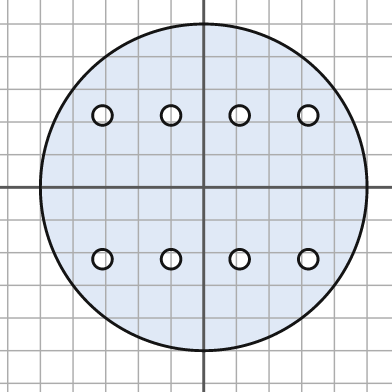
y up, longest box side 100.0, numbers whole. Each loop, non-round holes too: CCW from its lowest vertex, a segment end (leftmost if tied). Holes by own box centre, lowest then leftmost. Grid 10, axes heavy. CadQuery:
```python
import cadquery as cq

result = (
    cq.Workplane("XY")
    .moveTo(0.0, 0.0)
    .circle(50.0)
    .moveTo(-31.0, -22.0)
    .circle(3.0)
    .moveTo(-10.0, -22.0)
    .circle(3.0)
    .moveTo(11.0, -22.0)
    .circle(3.0)
    .moveTo(32.0, -22.0)
    .circle(3.0)
    .moveTo(-31.0, 22.0)
    .circle(3.0)
    .moveTo(-10.0, 22.0)
    .circle(3.0)
    .moveTo(11.0, 22.0)
    .circle(3.0)
    .moveTo(32.0, 22.0)
    .circle(3.0)
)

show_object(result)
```